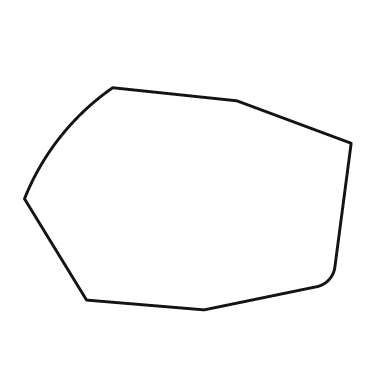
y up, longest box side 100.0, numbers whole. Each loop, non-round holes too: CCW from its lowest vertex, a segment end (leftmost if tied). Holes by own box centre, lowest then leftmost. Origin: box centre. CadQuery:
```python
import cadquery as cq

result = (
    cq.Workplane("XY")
    .moveTo(5.0, -34.0)
    .lineTo(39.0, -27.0)
    .threePointArc((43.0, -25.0), (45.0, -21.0))
    .lineTo(50.0, 17.0)
    .lineTo(15.0, 30.0)
    .lineTo(-23.0, 34.0)
    .threePointArc((-39.0, 19.0), (-50.0, 0.0))
    .lineTo(-31.0, -31.0)
    .close()
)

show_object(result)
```